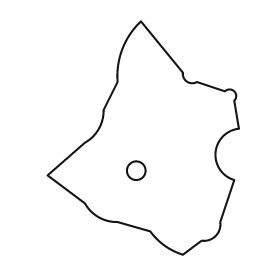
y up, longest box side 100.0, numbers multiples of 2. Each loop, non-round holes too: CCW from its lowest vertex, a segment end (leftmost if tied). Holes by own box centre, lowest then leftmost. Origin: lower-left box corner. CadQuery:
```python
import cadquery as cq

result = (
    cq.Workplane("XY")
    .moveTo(58.0, 0.0)
    .lineTo(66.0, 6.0)
    .threePointArc((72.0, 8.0), (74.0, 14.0))
    .lineTo(80.0, 32.0)
    .threePointArc((72.0, 44.0), (82.0, 54.0))
    .lineTo(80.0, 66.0)
    .threePointArc((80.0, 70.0), (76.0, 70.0))
    .lineTo(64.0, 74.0)
    .threePointArc((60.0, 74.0), (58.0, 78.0))
    .lineTo(40.0, 100.0)
    .threePointArc((32.0, 88.0), (30.0, 74.0))
    .lineTo(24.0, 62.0)
    .threePointArc((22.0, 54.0), (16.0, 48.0))
    .lineTo(0.0, 34.0)
    .lineTo(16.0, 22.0)
    .threePointArc((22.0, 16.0), (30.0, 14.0))
    .lineTo(44.0, 10.0)
    .threePointArc((50.0, 4.0), (58.0, 0.0))
    .close()
    .moveTo(38.0, 36.0)
    .circle(4.0)
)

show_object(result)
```